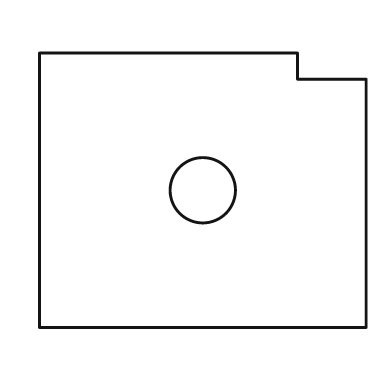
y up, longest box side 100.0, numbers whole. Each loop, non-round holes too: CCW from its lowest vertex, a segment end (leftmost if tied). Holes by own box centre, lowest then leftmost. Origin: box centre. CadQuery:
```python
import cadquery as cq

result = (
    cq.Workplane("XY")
    .moveTo(-50.0, -42.0)
    .lineTo(50.0, -42.0)
    .lineTo(50.0, 34.0)
    .lineTo(29.0, 34.0)
    .lineTo(29.0, 42.0)
    .lineTo(-50.0, 42.0)
    .close()
    .moveTo(0.0, 0.0)
    .circle(10.0)
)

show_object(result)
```